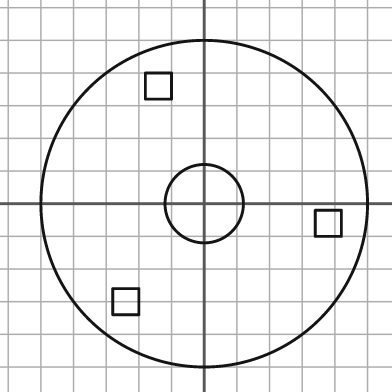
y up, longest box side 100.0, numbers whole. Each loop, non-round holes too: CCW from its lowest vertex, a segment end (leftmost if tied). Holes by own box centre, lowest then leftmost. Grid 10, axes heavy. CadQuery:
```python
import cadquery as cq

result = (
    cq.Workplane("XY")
    .moveTo(0.0, 0.0)
    .circle(50.0)
    .moveTo(-28.0, -34.0)
    .lineTo(-20.0, -34.0)
    .lineTo(-20.0, -26.0)
    .lineTo(-28.0, -26.0)
    .close()
    .moveTo(34.0, -10.0)
    .lineTo(42.0, -10.0)
    .lineTo(42.0, -2.0)
    .lineTo(34.0, -2.0)
    .close()
    .moveTo(0.0, 0.0)
    .circle(12.0)
    .moveTo(-18.0, 32.0)
    .lineTo(-10.0, 32.0)
    .lineTo(-10.0, 40.0)
    .lineTo(-18.0, 40.0)
    .close()
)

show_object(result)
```